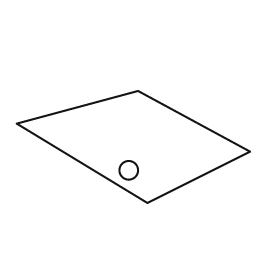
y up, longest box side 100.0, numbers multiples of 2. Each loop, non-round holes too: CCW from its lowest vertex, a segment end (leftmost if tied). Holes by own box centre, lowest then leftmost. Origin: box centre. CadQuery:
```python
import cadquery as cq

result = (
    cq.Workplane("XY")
    .moveTo(6.0, -24.0)
    .lineTo(50.0, -2.0)
    .lineTo(2.0, 24.0)
    .lineTo(-50.0, 10.0)
    .close()
    .moveTo(-2.0, -10.0)
    .circle(4.0)
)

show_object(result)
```